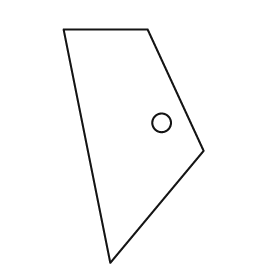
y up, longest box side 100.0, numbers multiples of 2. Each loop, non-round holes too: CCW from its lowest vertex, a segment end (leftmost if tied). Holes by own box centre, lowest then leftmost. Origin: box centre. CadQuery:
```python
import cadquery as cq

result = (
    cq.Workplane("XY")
    .moveTo(-10.0, -50.0)
    .lineTo(30.0, -2.0)
    .lineTo(6.0, 50.0)
    .lineTo(-30.0, 50.0)
    .close()
    .moveTo(12.0, 10.0)
    .circle(4.0)
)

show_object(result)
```